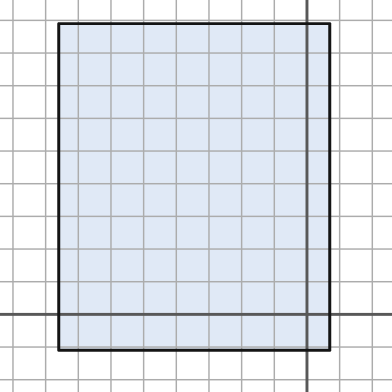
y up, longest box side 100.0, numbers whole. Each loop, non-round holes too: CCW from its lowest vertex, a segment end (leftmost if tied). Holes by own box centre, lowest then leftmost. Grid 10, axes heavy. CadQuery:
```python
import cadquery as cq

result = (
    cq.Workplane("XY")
    .moveTo(-76.0, -11.0)
    .lineTo(7.0, -11.0)
    .lineTo(7.0, 89.0)
    .lineTo(-76.0, 89.0)
    .close()
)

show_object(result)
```